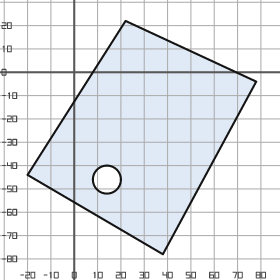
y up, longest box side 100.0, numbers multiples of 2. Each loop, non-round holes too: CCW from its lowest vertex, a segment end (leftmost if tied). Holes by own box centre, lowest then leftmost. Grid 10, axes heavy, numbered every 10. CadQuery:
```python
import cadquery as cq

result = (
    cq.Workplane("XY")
    .moveTo(38.0, -78.0)
    .lineTo(78.0, -4.0)
    .lineTo(22.0, 22.0)
    .lineTo(-20.0, -44.0)
    .close()
    .moveTo(14.0, -46.0)
    .circle(6.0)
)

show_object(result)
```